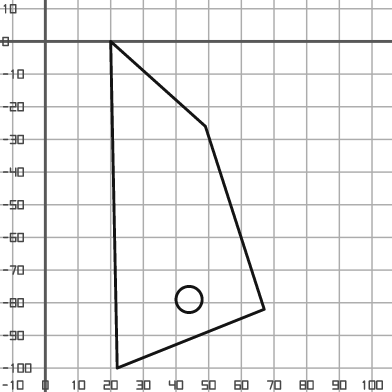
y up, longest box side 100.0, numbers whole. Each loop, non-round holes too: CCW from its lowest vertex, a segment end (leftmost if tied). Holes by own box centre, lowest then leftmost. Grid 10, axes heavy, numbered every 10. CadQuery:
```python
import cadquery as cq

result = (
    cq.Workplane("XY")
    .moveTo(22.0, -100.0)
    .lineTo(67.0, -82.0)
    .lineTo(49.0, -26.0)
    .lineTo(20.0, 0.0)
    .close()
    .moveTo(44.0, -79.0)
    .circle(4.0)
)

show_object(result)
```